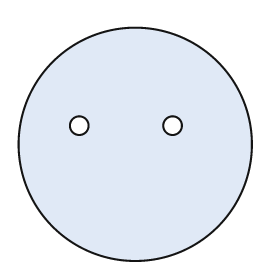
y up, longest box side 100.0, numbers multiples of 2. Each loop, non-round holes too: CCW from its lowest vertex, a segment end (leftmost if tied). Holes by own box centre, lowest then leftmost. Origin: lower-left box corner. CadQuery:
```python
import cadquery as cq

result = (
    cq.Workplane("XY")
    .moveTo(50.0, 50.0)
    .circle(50.0)
    .moveTo(26.0, 58.0)
    .circle(4.0)
    .moveTo(66.0, 58.0)
    .circle(4.0)
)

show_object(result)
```